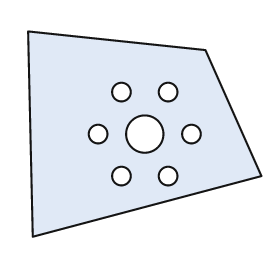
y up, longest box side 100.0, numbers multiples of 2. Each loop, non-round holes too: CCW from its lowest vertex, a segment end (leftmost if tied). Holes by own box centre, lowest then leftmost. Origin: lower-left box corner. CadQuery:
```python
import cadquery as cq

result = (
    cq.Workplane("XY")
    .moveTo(2.0, 0.0)
    .lineTo(100.0, 26.0)
    .lineTo(76.0, 80.0)
    .lineTo(0.0, 88.0)
    .close()
    .moveTo(40.0, 26.0)
    .circle(4.0)
    .moveTo(60.0, 26.0)
    .circle(4.0)
    .moveTo(30.0, 44.0)
    .circle(4.0)
    .moveTo(50.0, 44.0)
    .circle(8.0)
    .moveTo(70.0, 44.0)
    .circle(4.0)
    .moveTo(40.0, 62.0)
    .circle(4.0)
    .moveTo(60.0, 62.0)
    .circle(4.0)
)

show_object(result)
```